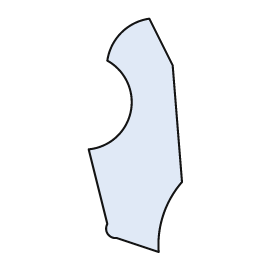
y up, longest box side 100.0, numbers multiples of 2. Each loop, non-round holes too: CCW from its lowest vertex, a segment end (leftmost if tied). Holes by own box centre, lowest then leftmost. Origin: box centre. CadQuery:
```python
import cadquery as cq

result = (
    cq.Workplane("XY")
    .moveTo(10.0, -50.0)
    .threePointArc((12.0, -34.0), (20.0, -20.0))
    .lineTo(16.0, 30.0)
    .lineTo(6.0, 50.0)
    .threePointArc((-6.0, 44.0), (-12.0, 32.0))
    .threePointArc((-2.0, 10.0), (-20.0, -6.0))
    .lineTo(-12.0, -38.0)
    .threePointArc((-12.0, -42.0), (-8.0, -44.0))
    .close()
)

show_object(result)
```